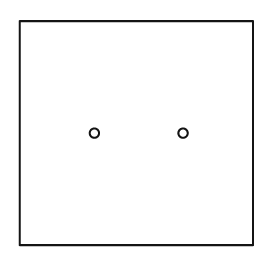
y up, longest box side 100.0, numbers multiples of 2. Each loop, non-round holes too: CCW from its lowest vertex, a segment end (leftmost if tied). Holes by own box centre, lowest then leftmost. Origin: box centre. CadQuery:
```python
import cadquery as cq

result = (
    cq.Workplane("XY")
    .moveTo(-50.0, -48.0)
    .lineTo(50.0, -48.0)
    .lineTo(50.0, 48.0)
    .lineTo(-50.0, 48.0)
    .close()
    .moveTo(-18.0, 0.0)
    .circle(2.0)
    .moveTo(20.0, 0.0)
    .circle(2.0)
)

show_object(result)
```